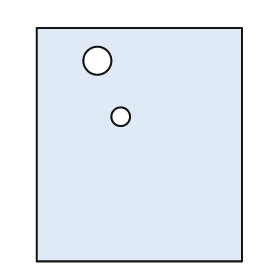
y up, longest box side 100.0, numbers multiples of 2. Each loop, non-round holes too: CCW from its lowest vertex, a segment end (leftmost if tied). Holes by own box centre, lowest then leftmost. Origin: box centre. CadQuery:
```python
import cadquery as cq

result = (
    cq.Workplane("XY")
    .moveTo(-44.0, -50.0)
    .lineTo(44.0, -50.0)
    .lineTo(44.0, 50.0)
    .lineTo(-44.0, 50.0)
    .close()
    .moveTo(-8.0, 12.0)
    .circle(4.0)
    .moveTo(-18.0, 36.0)
    .circle(6.0)
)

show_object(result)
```